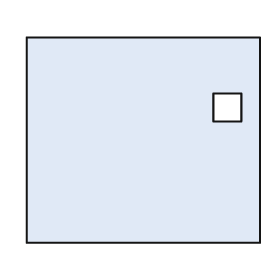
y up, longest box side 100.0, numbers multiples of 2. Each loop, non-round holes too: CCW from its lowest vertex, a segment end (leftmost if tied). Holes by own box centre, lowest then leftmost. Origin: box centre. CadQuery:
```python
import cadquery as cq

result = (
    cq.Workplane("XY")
    .moveTo(-50.0, -44.0)
    .lineTo(50.0, -44.0)
    .lineTo(50.0, 44.0)
    .lineTo(-50.0, 44.0)
    .close()
    .moveTo(30.0, 8.0)
    .lineTo(42.0, 8.0)
    .lineTo(42.0, 20.0)
    .lineTo(30.0, 20.0)
    .close()
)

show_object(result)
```